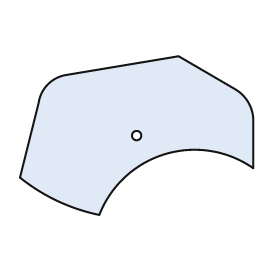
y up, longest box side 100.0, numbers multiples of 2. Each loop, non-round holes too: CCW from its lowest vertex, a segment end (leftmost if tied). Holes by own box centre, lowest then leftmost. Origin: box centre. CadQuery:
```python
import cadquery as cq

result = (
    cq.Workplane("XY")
    .moveTo(-16.0, -34.0)
    .threePointArc((12.0, -8.0), (50.0, -14.0))
    .lineTo(50.0, 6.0)
    .threePointArc((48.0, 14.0), (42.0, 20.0))
    .lineTo(18.0, 34.0)
    .lineTo(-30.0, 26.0)
    .threePointArc((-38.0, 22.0), (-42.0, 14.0))
    .lineTo(-50.0, -18.0)
    .threePointArc((-34.0, -28.0), (-16.0, -34.0))
    .close()
    .moveTo(0.0, 0.0)
    .circle(2.0)
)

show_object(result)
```